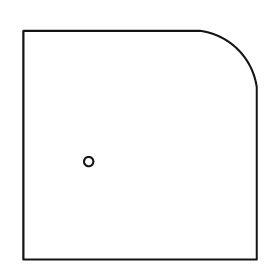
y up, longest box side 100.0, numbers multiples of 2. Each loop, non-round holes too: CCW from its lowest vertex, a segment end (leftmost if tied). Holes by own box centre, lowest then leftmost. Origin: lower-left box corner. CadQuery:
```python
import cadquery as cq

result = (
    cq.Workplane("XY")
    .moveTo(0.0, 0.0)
    .lineTo(100.0, 0.0)
    .lineTo(100.0, 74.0)
    .threePointArc((92.0, 90.0), (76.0, 98.0))
    .lineTo(0.0, 98.0)
    .close()
    .moveTo(28.0, 42.0)
    .circle(2.0)
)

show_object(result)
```